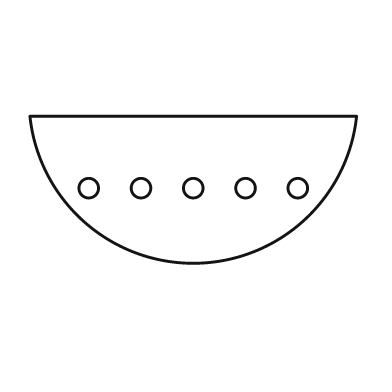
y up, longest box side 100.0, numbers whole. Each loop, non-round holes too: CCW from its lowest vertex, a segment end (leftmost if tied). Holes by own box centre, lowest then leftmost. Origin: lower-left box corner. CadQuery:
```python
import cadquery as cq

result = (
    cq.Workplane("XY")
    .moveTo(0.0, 45.0)
    .threePointArc((50.0, 0.0), (100.0, 45.0))
    .close()
    .moveTo(18.0, 23.0)
    .circle(3.0)
    .moveTo(34.0, 23.0)
    .circle(3.0)
    .moveTo(50.0, 23.0)
    .circle(3.0)
    .moveTo(66.0, 23.0)
    .circle(3.0)
    .moveTo(82.0, 23.0)
    .circle(3.0)
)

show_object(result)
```